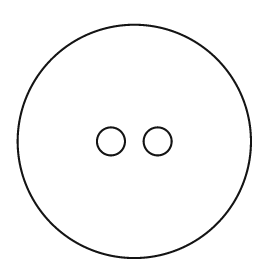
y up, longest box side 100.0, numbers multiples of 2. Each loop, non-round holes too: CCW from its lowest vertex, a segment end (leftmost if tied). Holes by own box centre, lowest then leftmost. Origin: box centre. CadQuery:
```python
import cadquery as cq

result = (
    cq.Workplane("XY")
    .moveTo(0.0, 0.0)
    .circle(50.0)
    .moveTo(-10.0, 0.0)
    .circle(6.0)
    .moveTo(10.0, 0.0)
    .circle(6.0)
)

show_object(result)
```